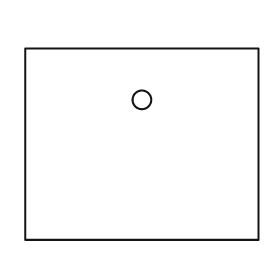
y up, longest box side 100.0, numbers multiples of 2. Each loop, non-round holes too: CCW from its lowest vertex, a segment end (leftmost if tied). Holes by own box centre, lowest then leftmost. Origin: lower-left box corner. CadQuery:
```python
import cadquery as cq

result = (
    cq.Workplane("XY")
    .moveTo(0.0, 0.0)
    .lineTo(100.0, 0.0)
    .lineTo(100.0, 82.0)
    .lineTo(0.0, 82.0)
    .close()
    .moveTo(50.0, 60.0)
    .circle(4.0)
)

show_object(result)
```